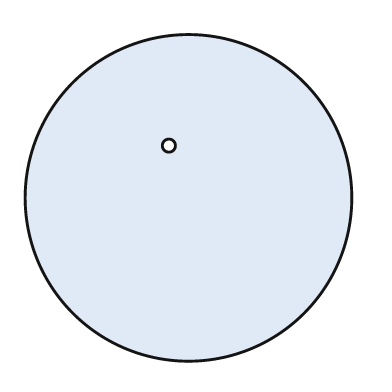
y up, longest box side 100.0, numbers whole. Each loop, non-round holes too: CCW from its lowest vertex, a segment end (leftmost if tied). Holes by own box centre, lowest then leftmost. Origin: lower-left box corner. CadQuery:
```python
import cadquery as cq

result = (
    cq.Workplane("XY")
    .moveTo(50.0, 50.0)
    .circle(50.0)
    .moveTo(44.0, 66.0)
    .circle(2.0)
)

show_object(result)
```